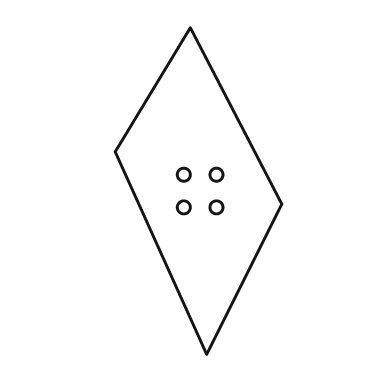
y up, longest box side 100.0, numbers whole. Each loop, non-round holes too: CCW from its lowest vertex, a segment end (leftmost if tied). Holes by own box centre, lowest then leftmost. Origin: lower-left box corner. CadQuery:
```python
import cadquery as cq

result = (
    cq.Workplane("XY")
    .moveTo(28.0, 0.0)
    .lineTo(51.0, 46.0)
    .lineTo(23.0, 100.0)
    .lineTo(0.0, 62.0)
    .close()
    .moveTo(21.0, 45.0)
    .circle(2.0)
    .moveTo(31.0, 45.0)
    .circle(2.0)
    .moveTo(21.0, 55.0)
    .circle(2.0)
    .moveTo(31.0, 55.0)
    .circle(2.0)
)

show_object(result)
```